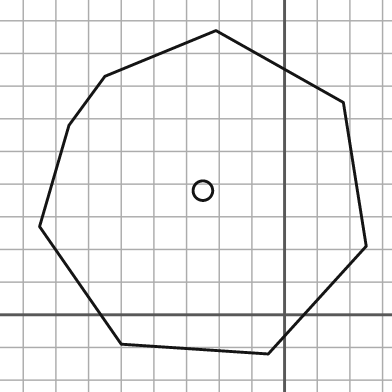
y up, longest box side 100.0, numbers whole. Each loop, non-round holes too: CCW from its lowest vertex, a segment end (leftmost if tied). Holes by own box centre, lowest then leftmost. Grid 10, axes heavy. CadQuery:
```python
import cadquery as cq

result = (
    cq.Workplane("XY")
    .moveTo(-5.0, -12.0)
    .lineTo(25.0, 21.0)
    .lineTo(18.0, 65.0)
    .lineTo(-21.0, 87.0)
    .lineTo(-55.0, 73.0)
    .lineTo(-66.0, 58.0)
    .lineTo(-75.0, 27.0)
    .lineTo(-50.0, -9.0)
    .close()
    .moveTo(-25.0, 38.0)
    .circle(3.0)
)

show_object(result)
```